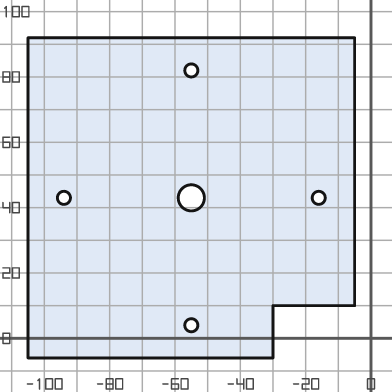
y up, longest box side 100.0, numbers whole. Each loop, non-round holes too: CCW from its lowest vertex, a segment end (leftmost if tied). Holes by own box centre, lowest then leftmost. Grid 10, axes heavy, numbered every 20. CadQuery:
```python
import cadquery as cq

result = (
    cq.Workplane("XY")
    .moveTo(-105.0, -6.0)
    .lineTo(-30.0, -6.0)
    .lineTo(-30.0, 10.0)
    .lineTo(-5.0, 10.0)
    .lineTo(-5.0, 92.0)
    .lineTo(-105.0, 92.0)
    .close()
    .moveTo(-55.0, 4.0)
    .circle(2.0)
    .moveTo(-94.0, 43.0)
    .circle(2.0)
    .moveTo(-55.0, 43.0)
    .circle(4.0)
    .moveTo(-16.0, 43.0)
    .circle(2.0)
    .moveTo(-55.0, 82.0)
    .circle(2.0)
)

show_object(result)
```